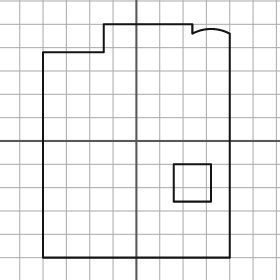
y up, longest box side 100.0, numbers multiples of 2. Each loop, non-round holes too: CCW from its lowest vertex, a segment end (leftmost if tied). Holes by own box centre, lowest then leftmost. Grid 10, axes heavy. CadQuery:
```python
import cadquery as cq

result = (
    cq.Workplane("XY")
    .moveTo(-40.0, -50.0)
    .lineTo(40.0, -50.0)
    .lineTo(40.0, 46.0)
    .threePointArc((32.0, 48.0), (24.0, 46.0))
    .lineTo(24.0, 50.0)
    .lineTo(-14.0, 50.0)
    .lineTo(-14.0, 38.0)
    .lineTo(-40.0, 38.0)
    .close()
    .moveTo(16.0, -26.0)
    .lineTo(32.0, -26.0)
    .lineTo(32.0, -10.0)
    .lineTo(16.0, -10.0)
    .close()
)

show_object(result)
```